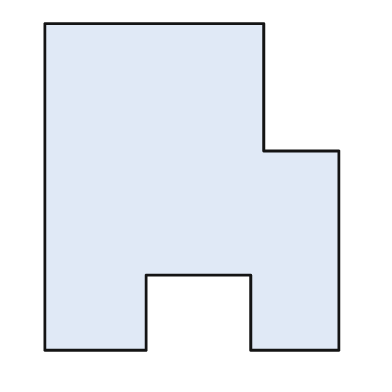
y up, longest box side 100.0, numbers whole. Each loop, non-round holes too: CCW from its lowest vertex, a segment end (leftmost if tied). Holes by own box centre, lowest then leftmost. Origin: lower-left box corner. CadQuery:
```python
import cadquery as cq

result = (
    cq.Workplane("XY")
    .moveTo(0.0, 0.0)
    .lineTo(31.0, 0.0)
    .lineTo(31.0, 23.0)
    .lineTo(63.0, 23.0)
    .lineTo(63.0, 0.0)
    .lineTo(90.0, 0.0)
    .lineTo(90.0, 61.0)
    .lineTo(67.0, 61.0)
    .lineTo(67.0, 100.0)
    .lineTo(0.0, 100.0)
    .close()
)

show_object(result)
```